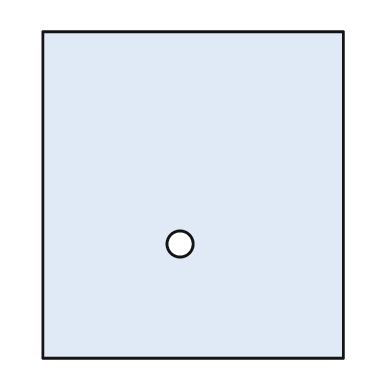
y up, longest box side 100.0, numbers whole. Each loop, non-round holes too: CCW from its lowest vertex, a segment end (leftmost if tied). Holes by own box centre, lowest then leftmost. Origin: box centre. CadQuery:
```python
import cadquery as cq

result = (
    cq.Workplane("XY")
    .moveTo(-46.0, -50.0)
    .lineTo(46.0, -50.0)
    .lineTo(46.0, 50.0)
    .lineTo(-46.0, 50.0)
    .close()
    .moveTo(-4.0, -15.0)
    .circle(4.0)
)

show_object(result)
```